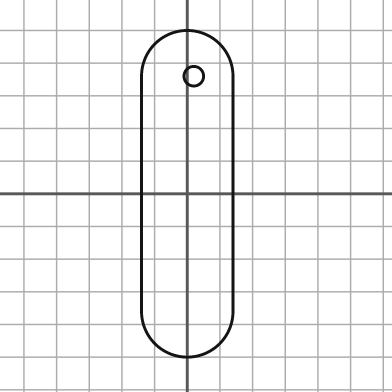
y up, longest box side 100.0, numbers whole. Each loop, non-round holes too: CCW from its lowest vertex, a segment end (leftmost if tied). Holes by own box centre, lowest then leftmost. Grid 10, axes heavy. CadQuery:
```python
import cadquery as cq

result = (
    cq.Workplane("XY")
    .moveTo(-14.0, -36.0)
    .threePointArc((0.0, -50.0), (14.0, -36.0))
    .lineTo(14.0, 36.0)
    .threePointArc((0.0, 50.0), (-14.0, 36.0))
    .close()
    .moveTo(2.0, 36.0)
    .circle(3.0)
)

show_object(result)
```